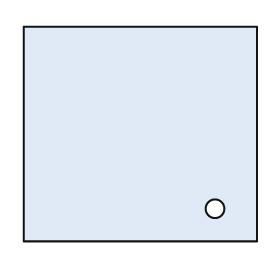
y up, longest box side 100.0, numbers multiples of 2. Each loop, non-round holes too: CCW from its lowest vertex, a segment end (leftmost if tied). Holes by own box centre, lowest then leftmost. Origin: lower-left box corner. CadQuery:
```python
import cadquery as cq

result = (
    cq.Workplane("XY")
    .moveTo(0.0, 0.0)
    .lineTo(100.0, 0.0)
    .lineTo(100.0, 92.0)
    .lineTo(0.0, 92.0)
    .close()
    .moveTo(82.0, 14.0)
    .circle(4.0)
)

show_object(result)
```